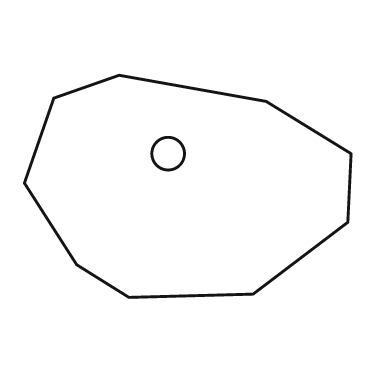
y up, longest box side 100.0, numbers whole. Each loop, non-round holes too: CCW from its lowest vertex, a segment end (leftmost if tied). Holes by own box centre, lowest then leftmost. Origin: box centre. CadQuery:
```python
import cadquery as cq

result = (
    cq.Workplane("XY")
    .moveTo(-18.0, -34.0)
    .lineTo(20.0, -33.0)
    .lineTo(49.0, -11.0)
    .lineTo(50.0, 10.0)
    .lineTo(24.0, 26.0)
    .lineTo(-21.0, 34.0)
    .lineTo(-41.0, 27.0)
    .lineTo(-50.0, 1.0)
    .lineTo(-34.0, -24.0)
    .close()
    .moveTo(-6.0, 10.0)
    .circle(5.0)
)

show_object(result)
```